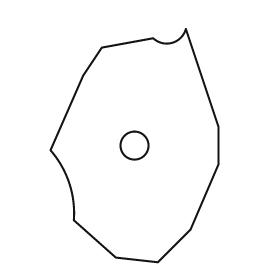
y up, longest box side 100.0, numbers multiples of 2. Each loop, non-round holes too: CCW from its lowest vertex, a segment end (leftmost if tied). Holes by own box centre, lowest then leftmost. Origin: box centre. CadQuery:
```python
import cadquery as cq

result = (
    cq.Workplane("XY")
    .moveTo(10.0, -50.0)
    .lineTo(24.0, -36.0)
    .lineTo(36.0, -8.0)
    .lineTo(36.0, 8.0)
    .lineTo(22.0, 50.0)
    .threePointArc((16.0, 44.0), (8.0, 46.0))
    .lineTo(-14.0, 42.0)
    .lineTo(-22.0, 30.0)
    .lineTo(-36.0, -2.0)
    .threePointArc((-28.0, -16.0), (-26.0, -32.0))
    .lineTo(-8.0, -48.0)
    .close()
    .moveTo(0.0, 0.0)
    .circle(6.0)
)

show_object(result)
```